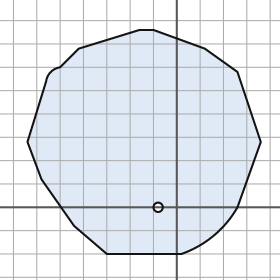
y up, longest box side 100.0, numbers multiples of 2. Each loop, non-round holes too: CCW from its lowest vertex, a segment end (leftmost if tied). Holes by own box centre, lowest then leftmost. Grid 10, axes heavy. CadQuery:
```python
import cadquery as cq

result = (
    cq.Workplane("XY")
    .moveTo(-30.0, -20.0)
    .lineTo(2.0, -20.0)
    .threePointArc((16.0, -12.0), (26.0, 0.0))
    .lineTo(36.0, 28.0)
    .lineTo(26.0, 58.0)
    .lineTo(12.0, 68.0)
    .lineTo(-10.0, 76.0)
    .lineTo(-16.0, 76.0)
    .lineTo(-42.0, 68.0)
    .lineTo(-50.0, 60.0)
    .threePointArc((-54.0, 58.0), (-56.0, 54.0))
    .lineTo(-64.0, 28.0)
    .lineTo(-58.0, 12.0)
    .lineTo(-44.0, -8.0)
    .close()
    .moveTo(-8.0, 0.0)
    .circle(2.0)
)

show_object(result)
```